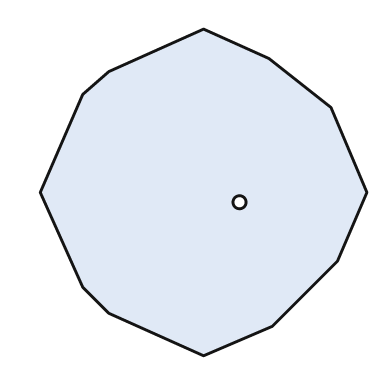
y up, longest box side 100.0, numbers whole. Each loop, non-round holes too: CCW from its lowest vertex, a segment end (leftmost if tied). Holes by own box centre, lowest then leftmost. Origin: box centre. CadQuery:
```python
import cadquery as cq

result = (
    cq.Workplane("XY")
    .moveTo(0.0, -50.0)
    .lineTo(21.0, -41.0)
    .lineTo(41.0, -21.0)
    .lineTo(50.0, 0.0)
    .lineTo(39.0, 26.0)
    .lineTo(20.0, 41.0)
    .lineTo(0.0, 50.0)
    .lineTo(-29.0, 37.0)
    .lineTo(-37.0, 30.0)
    .lineTo(-50.0, 0.0)
    .lineTo(-37.0, -29.0)
    .lineTo(-29.0, -37.0)
    .close()
    .moveTo(11.0, -3.0)
    .circle(2.0)
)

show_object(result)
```